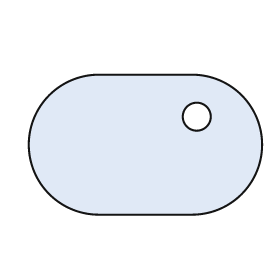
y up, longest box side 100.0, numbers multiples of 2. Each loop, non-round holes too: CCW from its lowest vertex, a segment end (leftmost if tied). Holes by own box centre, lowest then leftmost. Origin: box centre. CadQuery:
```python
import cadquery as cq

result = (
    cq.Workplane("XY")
    .moveTo(-20.0, -30.0)
    .lineTo(20.0, -30.0)
    .threePointArc((50.0, 0.0), (20.0, 30.0))
    .lineTo(-20.0, 30.0)
    .threePointArc((-50.0, 0.0), (-20.0, -30.0))
    .close()
    .moveTo(22.0, 12.0)
    .circle(6.0)
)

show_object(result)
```